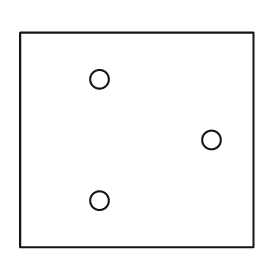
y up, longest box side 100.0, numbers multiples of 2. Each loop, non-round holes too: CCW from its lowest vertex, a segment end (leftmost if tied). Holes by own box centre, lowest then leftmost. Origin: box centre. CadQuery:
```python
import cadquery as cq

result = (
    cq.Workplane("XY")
    .moveTo(-50.0, -46.0)
    .lineTo(50.0, -46.0)
    .lineTo(50.0, 46.0)
    .lineTo(-50.0, 46.0)
    .close()
    .moveTo(-16.0, -26.0)
    .circle(4.0)
    .moveTo(32.0, 0.0)
    .circle(4.0)
    .moveTo(-16.0, 26.0)
    .circle(4.0)
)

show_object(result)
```